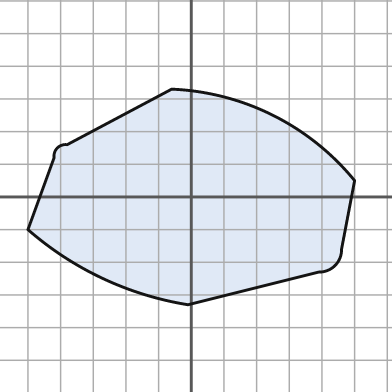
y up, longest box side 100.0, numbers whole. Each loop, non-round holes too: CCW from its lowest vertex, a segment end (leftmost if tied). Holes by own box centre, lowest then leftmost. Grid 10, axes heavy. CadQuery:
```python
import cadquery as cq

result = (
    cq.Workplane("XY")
    .moveTo(-1.0, -33.0)
    .lineTo(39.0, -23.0)
    .threePointArc((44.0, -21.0), (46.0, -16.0))
    .lineTo(50.0, 5.0)
    .threePointArc((25.0, 25.0), (-6.0, 33.0))
    .lineTo(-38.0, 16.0)
    .threePointArc((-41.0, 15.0), (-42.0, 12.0))
    .lineTo(-50.0, -10.0)
    .threePointArc((-27.0, -25.0), (-1.0, -33.0))
    .close()
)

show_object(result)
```